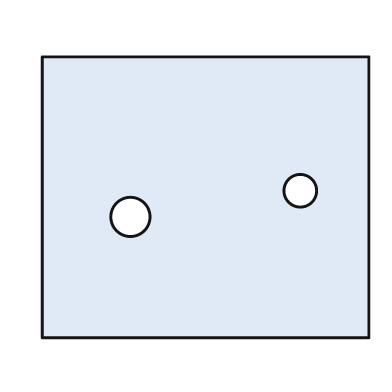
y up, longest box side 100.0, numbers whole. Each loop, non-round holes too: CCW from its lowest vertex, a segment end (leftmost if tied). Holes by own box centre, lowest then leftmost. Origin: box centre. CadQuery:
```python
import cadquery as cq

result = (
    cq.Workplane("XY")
    .moveTo(-50.0, -43.0)
    .lineTo(50.0, -43.0)
    .lineTo(50.0, 43.0)
    .lineTo(-50.0, 43.0)
    .close()
    .moveTo(-23.0, -6.0)
    .circle(6.0)
    .moveTo(29.0, 2.0)
    .circle(5.0)
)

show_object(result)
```